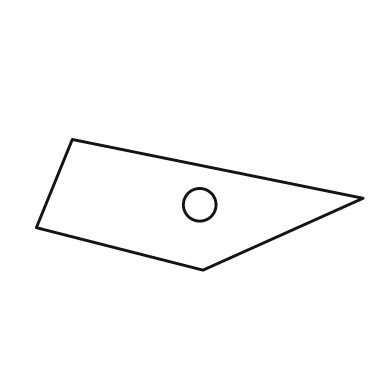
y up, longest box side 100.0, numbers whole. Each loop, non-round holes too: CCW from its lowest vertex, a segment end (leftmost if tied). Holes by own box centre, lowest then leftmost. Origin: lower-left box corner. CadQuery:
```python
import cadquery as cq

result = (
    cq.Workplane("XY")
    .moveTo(51.0, 0.0)
    .lineTo(100.0, 22.0)
    .lineTo(11.0, 40.0)
    .lineTo(0.0, 13.0)
    .close()
    .moveTo(50.0, 20.0)
    .circle(5.0)
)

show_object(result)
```